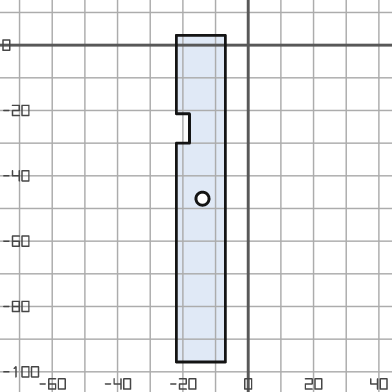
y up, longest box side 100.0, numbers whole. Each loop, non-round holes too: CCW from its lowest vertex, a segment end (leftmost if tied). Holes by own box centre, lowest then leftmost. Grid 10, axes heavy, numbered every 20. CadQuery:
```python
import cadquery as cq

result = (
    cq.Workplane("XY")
    .moveTo(-22.0, -97.0)
    .lineTo(-7.0, -97.0)
    .lineTo(-7.0, 3.0)
    .lineTo(-22.0, 3.0)
    .lineTo(-22.0, -21.0)
    .lineTo(-18.0, -21.0)
    .lineTo(-18.0, -30.0)
    .lineTo(-22.0, -30.0)
    .close()
    .moveTo(-14.0, -47.0)
    .circle(2.0)
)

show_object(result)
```